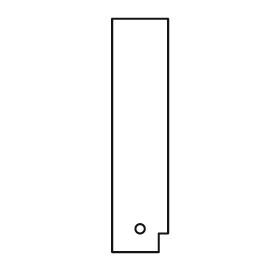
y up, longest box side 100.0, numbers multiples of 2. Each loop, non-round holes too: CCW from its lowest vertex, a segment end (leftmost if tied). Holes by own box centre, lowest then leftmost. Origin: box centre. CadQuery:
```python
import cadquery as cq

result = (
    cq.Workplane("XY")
    .moveTo(-12.0, -50.0)
    .lineTo(8.0, -50.0)
    .lineTo(8.0, -42.0)
    .lineTo(12.0, -42.0)
    .lineTo(12.0, 50.0)
    .lineTo(-12.0, 50.0)
    .close()
    .moveTo(0.0, -40.0)
    .circle(2.0)
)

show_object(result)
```